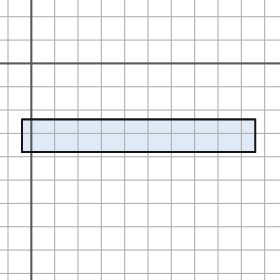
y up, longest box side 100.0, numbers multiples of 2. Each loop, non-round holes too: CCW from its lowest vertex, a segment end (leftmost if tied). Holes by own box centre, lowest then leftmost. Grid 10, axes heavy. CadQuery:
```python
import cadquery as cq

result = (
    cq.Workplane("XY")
    .moveTo(-4.0, -38.0)
    .lineTo(96.0, -38.0)
    .lineTo(96.0, -24.0)
    .lineTo(-4.0, -24.0)
    .close()
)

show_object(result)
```